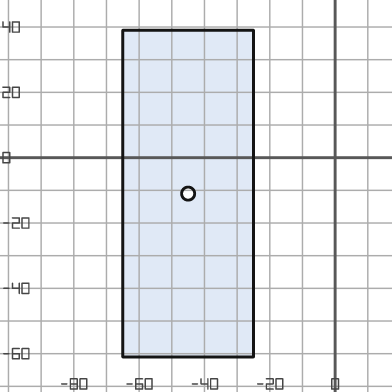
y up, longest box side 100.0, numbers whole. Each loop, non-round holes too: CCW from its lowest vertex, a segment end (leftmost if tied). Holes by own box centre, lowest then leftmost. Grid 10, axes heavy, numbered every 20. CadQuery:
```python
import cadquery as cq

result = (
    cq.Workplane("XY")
    .moveTo(-65.0, -61.0)
    .lineTo(-25.0, -61.0)
    .lineTo(-25.0, 39.0)
    .lineTo(-65.0, 39.0)
    .close()
    .moveTo(-45.0, -11.0)
    .circle(2.0)
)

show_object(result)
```